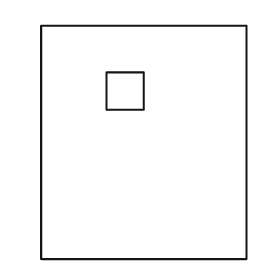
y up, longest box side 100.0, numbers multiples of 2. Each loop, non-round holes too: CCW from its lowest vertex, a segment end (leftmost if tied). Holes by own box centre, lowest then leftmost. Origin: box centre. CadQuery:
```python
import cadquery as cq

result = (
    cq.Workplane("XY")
    .moveTo(-44.0, -50.0)
    .lineTo(44.0, -50.0)
    .lineTo(44.0, 50.0)
    .lineTo(-44.0, 50.0)
    .close()
    .moveTo(-16.0, 14.0)
    .lineTo(0.0, 14.0)
    .lineTo(0.0, 30.0)
    .lineTo(-16.0, 30.0)
    .close()
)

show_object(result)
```